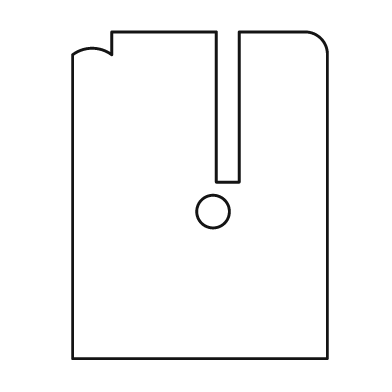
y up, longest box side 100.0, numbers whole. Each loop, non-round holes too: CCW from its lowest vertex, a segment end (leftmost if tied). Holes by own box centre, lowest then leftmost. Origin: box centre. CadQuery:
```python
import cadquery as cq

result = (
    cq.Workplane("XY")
    .moveTo(-39.0, -50.0)
    .lineTo(39.0, -50.0)
    .lineTo(39.0, 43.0)
    .threePointArc((37.0, 48.0), (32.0, 50.0))
    .lineTo(12.0, 50.0)
    .lineTo(12.0, 4.0)
    .lineTo(5.0, 4.0)
    .lineTo(5.0, 50.0)
    .lineTo(-27.0, 50.0)
    .lineTo(-27.0, 43.0)
    .threePointArc((-33.0, 45.0), (-39.0, 43.0))
    .close()
    .moveTo(4.0, -5.0)
    .circle(5.0)
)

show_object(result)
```